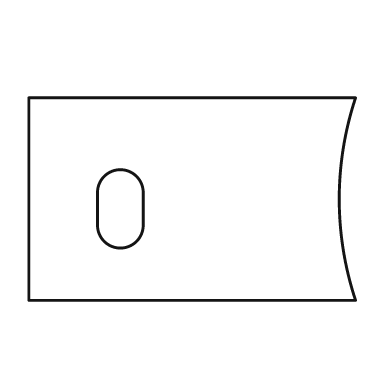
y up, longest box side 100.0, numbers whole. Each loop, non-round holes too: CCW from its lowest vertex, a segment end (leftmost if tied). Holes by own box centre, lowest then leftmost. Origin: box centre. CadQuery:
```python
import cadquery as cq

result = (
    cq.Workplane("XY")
    .moveTo(-50.0, -31.0)
    .lineTo(50.0, -31.0)
    .threePointArc((45.0, 0.0), (50.0, 31.0))
    .lineTo(-50.0, 31.0)
    .close()
    .moveTo(-29.0, -8.0)
    .threePointArc((-22.0, -15.0), (-15.0, -8.0))
    .lineTo(-15.0, 2.0)
    .threePointArc((-22.0, 9.0), (-29.0, 2.0))
    .close()
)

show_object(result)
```